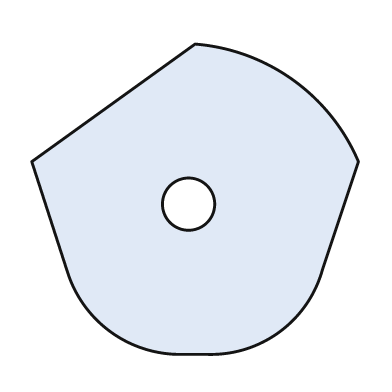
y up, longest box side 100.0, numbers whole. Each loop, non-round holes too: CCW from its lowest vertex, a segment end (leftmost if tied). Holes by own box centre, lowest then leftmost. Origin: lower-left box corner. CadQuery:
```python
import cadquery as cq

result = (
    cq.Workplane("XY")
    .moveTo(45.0, 0.0)
    .lineTo(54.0, 0.0)
    .threePointArc((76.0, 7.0), (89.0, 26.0))
    .lineTo(100.0, 59.0)
    .threePointArc((80.0, 84.0), (50.0, 95.0))
    .lineTo(0.0, 59.0)
    .lineTo(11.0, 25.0)
    .threePointArc((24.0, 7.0), (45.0, 0.0))
    .close()
    .moveTo(48.0, 46.0)
    .circle(8.0)
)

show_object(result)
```